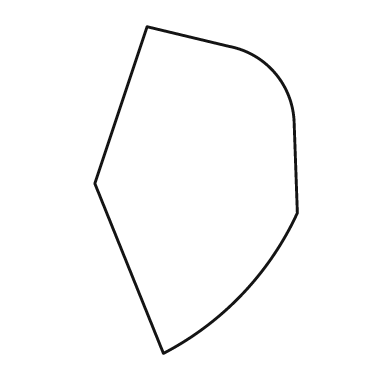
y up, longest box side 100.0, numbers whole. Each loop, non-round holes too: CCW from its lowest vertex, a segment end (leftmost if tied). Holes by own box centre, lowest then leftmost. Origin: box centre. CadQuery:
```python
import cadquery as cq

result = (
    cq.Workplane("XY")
    .moveTo(-10.0, -50.0)
    .threePointArc((14.0, -32.0), (31.0, -7.0))
    .lineTo(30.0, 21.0)
    .threePointArc((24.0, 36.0), (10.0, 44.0))
    .lineTo(-15.0, 50.0)
    .lineTo(-31.0, 2.0)
    .close()
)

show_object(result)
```